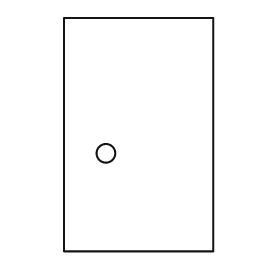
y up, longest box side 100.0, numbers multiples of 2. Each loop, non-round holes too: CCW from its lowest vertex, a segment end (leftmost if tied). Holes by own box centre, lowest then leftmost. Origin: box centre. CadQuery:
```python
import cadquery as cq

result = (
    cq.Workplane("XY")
    .moveTo(-32.0, -50.0)
    .lineTo(32.0, -50.0)
    .lineTo(32.0, 50.0)
    .lineTo(-32.0, 50.0)
    .close()
    .moveTo(-14.0, -8.0)
    .circle(4.0)
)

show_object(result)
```